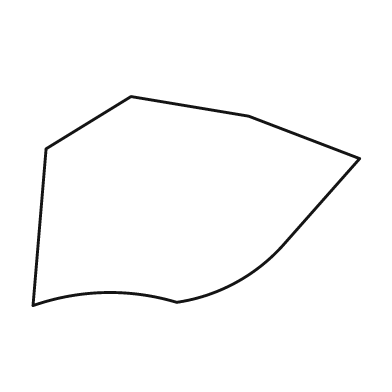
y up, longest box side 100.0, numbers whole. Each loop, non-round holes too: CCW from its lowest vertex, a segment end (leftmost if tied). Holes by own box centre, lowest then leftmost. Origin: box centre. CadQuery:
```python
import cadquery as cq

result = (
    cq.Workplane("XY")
    .moveTo(-50.0, -32.0)
    .threePointArc((-28.0, -28.0), (-6.0, -31.0))
    .threePointArc((12.0, -25.0), (27.0, -13.0))
    .lineTo(50.0, 13.0)
    .lineTo(16.0, 26.0)
    .lineTo(-20.0, 32.0)
    .lineTo(-46.0, 16.0)
    .close()
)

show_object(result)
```